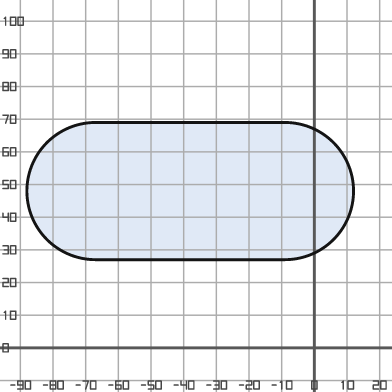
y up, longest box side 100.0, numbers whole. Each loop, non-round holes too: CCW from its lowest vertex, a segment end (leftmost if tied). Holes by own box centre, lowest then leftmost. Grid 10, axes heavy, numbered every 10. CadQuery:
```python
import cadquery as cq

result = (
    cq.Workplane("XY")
    .moveTo(-67.0, 27.0)
    .lineTo(-9.0, 27.0)
    .threePointArc((12.0, 48.0), (-9.0, 69.0))
    .lineTo(-67.0, 69.0)
    .threePointArc((-88.0, 48.0), (-67.0, 27.0))
    .close()
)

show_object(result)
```